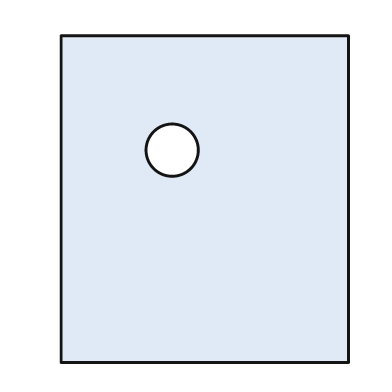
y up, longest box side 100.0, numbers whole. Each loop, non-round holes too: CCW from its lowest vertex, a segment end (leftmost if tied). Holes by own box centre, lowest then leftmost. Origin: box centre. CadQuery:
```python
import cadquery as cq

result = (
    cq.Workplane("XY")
    .moveTo(-44.0, -50.0)
    .lineTo(44.0, -50.0)
    .lineTo(44.0, 50.0)
    .lineTo(-44.0, 50.0)
    .close()
    .moveTo(-10.0, 15.0)
    .circle(8.0)
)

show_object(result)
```